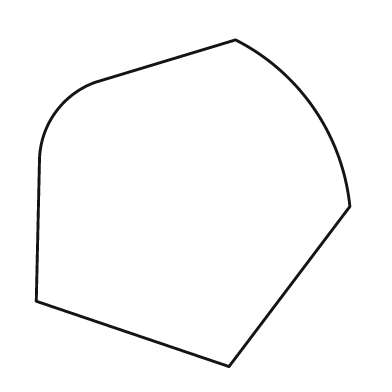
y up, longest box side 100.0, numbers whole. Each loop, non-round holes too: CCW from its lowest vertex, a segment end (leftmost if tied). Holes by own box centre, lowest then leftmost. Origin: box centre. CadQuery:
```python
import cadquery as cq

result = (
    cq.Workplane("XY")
    .moveTo(11.0, -50.0)
    .lineTo(48.0, -1.0)
    .threePointArc((37.0, 29.0), (13.0, 50.0))
    .lineTo(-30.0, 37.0)
    .threePointArc((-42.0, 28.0), (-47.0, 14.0))
    .lineTo(-48.0, -30.0)
    .close()
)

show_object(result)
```